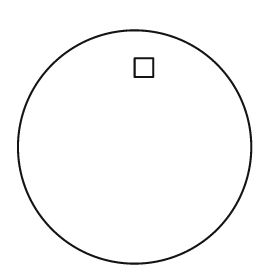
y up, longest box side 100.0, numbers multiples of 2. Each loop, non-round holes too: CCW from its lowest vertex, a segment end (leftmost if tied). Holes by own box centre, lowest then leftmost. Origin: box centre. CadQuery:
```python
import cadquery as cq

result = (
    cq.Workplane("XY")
    .moveTo(0.0, 0.0)
    .circle(50.0)
    .moveTo(0.0, 30.0)
    .lineTo(8.0, 30.0)
    .lineTo(8.0, 38.0)
    .lineTo(0.0, 38.0)
    .close()
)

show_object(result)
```